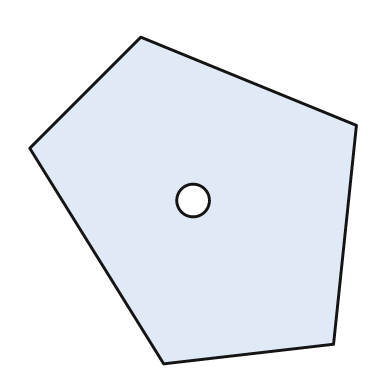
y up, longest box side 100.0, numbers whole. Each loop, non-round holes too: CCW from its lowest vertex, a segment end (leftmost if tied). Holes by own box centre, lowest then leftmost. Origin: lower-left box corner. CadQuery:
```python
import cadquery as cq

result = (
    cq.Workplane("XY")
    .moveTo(41.0, 0.0)
    .lineTo(93.0, 6.0)
    .lineTo(100.0, 73.0)
    .lineTo(34.0, 100.0)
    .lineTo(0.0, 66.0)
    .close()
    .moveTo(50.0, 50.0)
    .circle(5.0)
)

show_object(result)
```